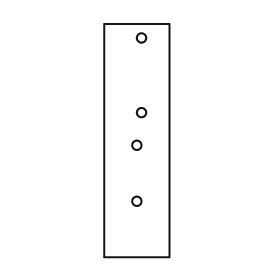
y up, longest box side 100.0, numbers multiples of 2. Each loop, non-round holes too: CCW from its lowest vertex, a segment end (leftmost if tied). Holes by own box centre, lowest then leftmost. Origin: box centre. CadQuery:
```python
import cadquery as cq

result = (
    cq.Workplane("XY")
    .moveTo(-14.0, -50.0)
    .lineTo(14.0, -50.0)
    .lineTo(14.0, 50.0)
    .lineTo(-14.0, 50.0)
    .close()
    .moveTo(0.0, -26.0)
    .circle(2.0)
    .moveTo(0.0, -2.0)
    .circle(2.0)
    .moveTo(2.0, 12.0)
    .circle(2.0)
    .moveTo(2.0, 44.0)
    .circle(2.0)
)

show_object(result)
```